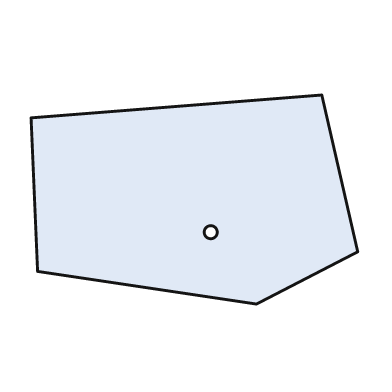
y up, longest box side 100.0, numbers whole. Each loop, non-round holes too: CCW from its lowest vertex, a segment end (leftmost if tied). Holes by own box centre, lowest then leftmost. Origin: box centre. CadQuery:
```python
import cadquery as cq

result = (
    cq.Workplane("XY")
    .moveTo(19.0, -32.0)
    .lineTo(50.0, -16.0)
    .lineTo(39.0, 32.0)
    .lineTo(-50.0, 25.0)
    .lineTo(-48.0, -22.0)
    .close()
    .moveTo(5.0, -10.0)
    .circle(2.0)
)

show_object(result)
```